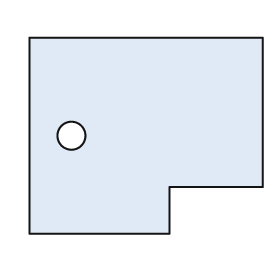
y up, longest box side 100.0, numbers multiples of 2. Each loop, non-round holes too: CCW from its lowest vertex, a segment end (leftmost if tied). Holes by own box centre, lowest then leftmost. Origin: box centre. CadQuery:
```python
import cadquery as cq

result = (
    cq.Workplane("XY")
    .moveTo(-50.0, -42.0)
    .lineTo(10.0, -42.0)
    .lineTo(10.0, -22.0)
    .lineTo(50.0, -22.0)
    .lineTo(50.0, 42.0)
    .lineTo(-50.0, 42.0)
    .close()
    .moveTo(-32.0, 0.0)
    .circle(6.0)
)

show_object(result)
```